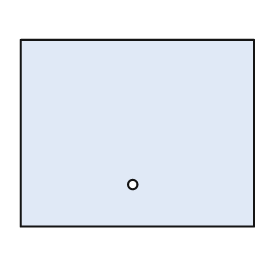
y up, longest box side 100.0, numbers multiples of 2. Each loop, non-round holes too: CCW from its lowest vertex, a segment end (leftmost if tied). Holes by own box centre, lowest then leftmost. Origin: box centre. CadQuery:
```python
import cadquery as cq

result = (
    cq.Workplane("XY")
    .moveTo(-50.0, -40.0)
    .lineTo(50.0, -40.0)
    .lineTo(50.0, 40.0)
    .lineTo(-50.0, 40.0)
    .close()
    .moveTo(-2.0, -22.0)
    .circle(2.0)
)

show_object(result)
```